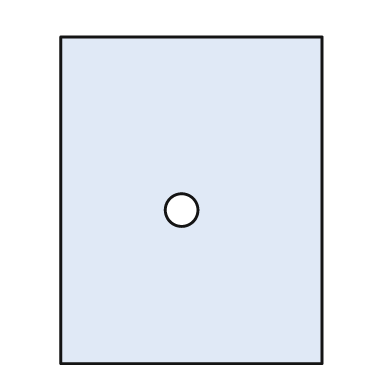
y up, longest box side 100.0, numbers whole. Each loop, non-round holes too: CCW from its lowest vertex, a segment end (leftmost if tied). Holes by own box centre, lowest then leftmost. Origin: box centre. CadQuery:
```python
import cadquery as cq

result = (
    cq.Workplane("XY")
    .moveTo(-40.0, -50.0)
    .lineTo(40.0, -50.0)
    .lineTo(40.0, 50.0)
    .lineTo(-40.0, 50.0)
    .close()
    .moveTo(-3.0, -3.0)
    .circle(5.0)
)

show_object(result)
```